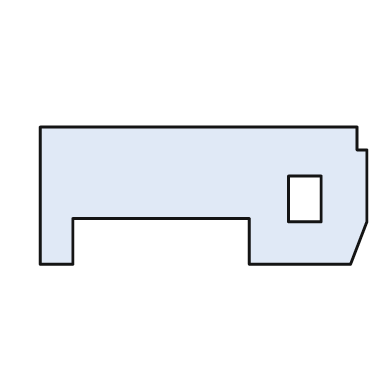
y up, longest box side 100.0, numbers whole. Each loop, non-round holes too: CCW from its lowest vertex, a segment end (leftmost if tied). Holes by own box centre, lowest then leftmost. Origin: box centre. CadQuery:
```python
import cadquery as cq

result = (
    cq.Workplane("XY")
    .moveTo(-50.0, -21.0)
    .lineTo(-40.0, -21.0)
    .lineTo(-40.0, -7.0)
    .lineTo(14.0, -7.0)
    .lineTo(14.0, -21.0)
    .lineTo(45.0, -21.0)
    .lineTo(50.0, -8.0)
    .lineTo(50.0, 14.0)
    .lineTo(47.0, 14.0)
    .lineTo(47.0, 21.0)
    .lineTo(-50.0, 21.0)
    .close()
    .moveTo(26.0, -8.0)
    .lineTo(36.0, -8.0)
    .lineTo(36.0, 6.0)
    .lineTo(26.0, 6.0)
    .close()
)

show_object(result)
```